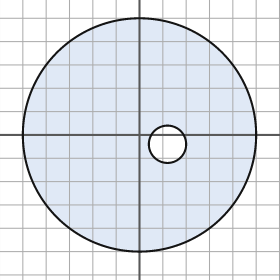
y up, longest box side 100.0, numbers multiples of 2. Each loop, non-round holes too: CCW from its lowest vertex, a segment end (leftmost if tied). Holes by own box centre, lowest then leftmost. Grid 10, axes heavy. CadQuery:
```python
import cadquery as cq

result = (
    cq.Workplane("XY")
    .moveTo(0.0, 0.0)
    .circle(50.0)
    .moveTo(12.0, -4.0)
    .circle(8.0)
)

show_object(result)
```